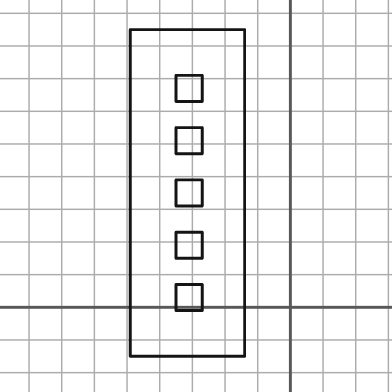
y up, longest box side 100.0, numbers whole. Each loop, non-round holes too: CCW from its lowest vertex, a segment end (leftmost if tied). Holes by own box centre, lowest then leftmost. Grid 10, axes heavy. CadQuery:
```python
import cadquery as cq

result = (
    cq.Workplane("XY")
    .moveTo(-49.0, -15.0)
    .lineTo(-14.0, -15.0)
    .lineTo(-14.0, 85.0)
    .lineTo(-49.0, 85.0)
    .close()
    .moveTo(-35.0, -1.0)
    .lineTo(-27.0, -1.0)
    .lineTo(-27.0, 7.0)
    .lineTo(-35.0, 7.0)
    .close()
    .moveTo(-35.0, 15.0)
    .lineTo(-27.0, 15.0)
    .lineTo(-27.0, 23.0)
    .lineTo(-35.0, 23.0)
    .close()
    .moveTo(-35.0, 31.0)
    .lineTo(-27.0, 31.0)
    .lineTo(-27.0, 39.0)
    .lineTo(-35.0, 39.0)
    .close()
    .moveTo(-35.0, 47.0)
    .lineTo(-27.0, 47.0)
    .lineTo(-27.0, 55.0)
    .lineTo(-35.0, 55.0)
    .close()
    .moveTo(-35.0, 63.0)
    .lineTo(-27.0, 63.0)
    .lineTo(-27.0, 71.0)
    .lineTo(-35.0, 71.0)
    .close()
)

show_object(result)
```